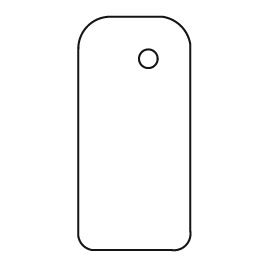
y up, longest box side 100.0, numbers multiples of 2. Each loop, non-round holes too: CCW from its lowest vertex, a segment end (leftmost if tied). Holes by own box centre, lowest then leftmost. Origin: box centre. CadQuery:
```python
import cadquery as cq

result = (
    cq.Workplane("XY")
    .moveTo(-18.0, -50.0)
    .lineTo(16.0, -50.0)
    .threePointArc((22.0, -48.0), (24.0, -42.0))
    .lineTo(24.0, 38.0)
    .threePointArc((20.0, 46.0), (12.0, 50.0))
    .lineTo(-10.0, 50.0)
    .threePointArc((-20.0, 46.0), (-24.0, 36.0))
    .lineTo(-24.0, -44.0)
    .threePointArc((-22.0, -48.0), (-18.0, -50.0))
    .close()
    .moveTo(6.0, 32.0)
    .circle(4.0)
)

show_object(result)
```